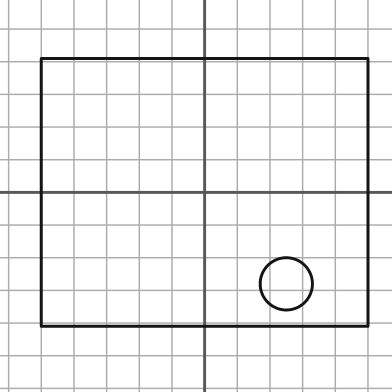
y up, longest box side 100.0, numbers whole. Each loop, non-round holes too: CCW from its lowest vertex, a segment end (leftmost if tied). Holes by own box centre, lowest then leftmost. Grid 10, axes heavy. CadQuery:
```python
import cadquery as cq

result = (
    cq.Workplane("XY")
    .moveTo(-50.0, -41.0)
    .lineTo(50.0, -41.0)
    .lineTo(50.0, 41.0)
    .lineTo(-50.0, 41.0)
    .close()
    .moveTo(25.0, -28.0)
    .circle(8.0)
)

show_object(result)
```